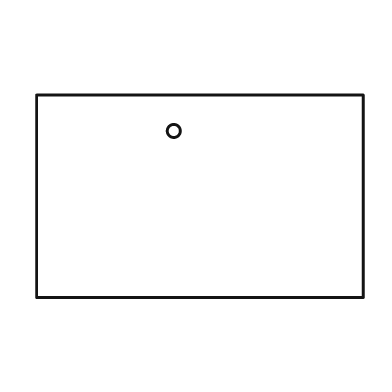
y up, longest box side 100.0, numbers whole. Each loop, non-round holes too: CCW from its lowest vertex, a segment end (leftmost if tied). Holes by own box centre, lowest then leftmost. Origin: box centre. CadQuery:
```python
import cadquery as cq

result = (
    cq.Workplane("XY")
    .moveTo(-50.0, -31.0)
    .lineTo(50.0, -31.0)
    .lineTo(50.0, 31.0)
    .lineTo(-50.0, 31.0)
    .close()
    .moveTo(-8.0, 20.0)
    .circle(2.0)
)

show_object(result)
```